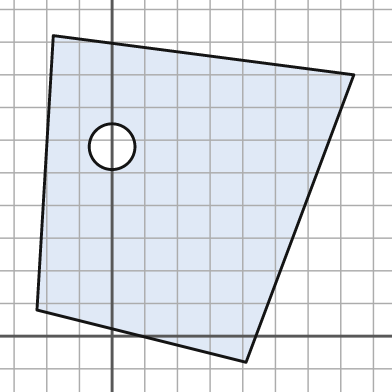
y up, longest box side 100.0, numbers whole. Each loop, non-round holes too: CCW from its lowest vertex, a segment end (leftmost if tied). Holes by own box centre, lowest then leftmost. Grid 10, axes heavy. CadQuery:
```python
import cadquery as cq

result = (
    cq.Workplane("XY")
    .moveTo(41.0, -8.0)
    .lineTo(74.0, 80.0)
    .lineTo(-18.0, 92.0)
    .lineTo(-23.0, 8.0)
    .close()
    .moveTo(0.0, 58.0)
    .circle(7.0)
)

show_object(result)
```